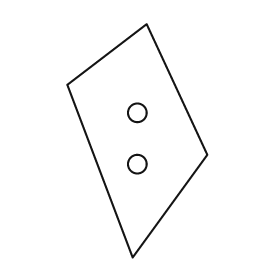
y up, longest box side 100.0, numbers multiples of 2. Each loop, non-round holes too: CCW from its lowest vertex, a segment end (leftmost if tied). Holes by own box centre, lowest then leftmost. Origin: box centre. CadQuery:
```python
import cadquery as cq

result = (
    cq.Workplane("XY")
    .moveTo(-2.0, -50.0)
    .lineTo(30.0, -6.0)
    .lineTo(4.0, 50.0)
    .lineTo(-30.0, 24.0)
    .close()
    .moveTo(0.0, -10.0)
    .circle(4.0)
    .moveTo(0.0, 12.0)
    .circle(4.0)
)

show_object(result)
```